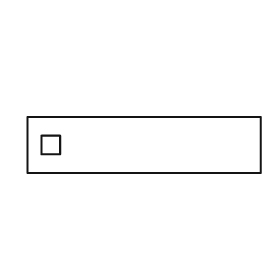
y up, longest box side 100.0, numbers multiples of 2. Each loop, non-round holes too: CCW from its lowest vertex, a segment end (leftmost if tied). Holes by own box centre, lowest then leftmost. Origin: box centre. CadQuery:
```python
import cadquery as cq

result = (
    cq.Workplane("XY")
    .moveTo(-50.0, -12.0)
    .lineTo(50.0, -12.0)
    .lineTo(50.0, 12.0)
    .lineTo(-50.0, 12.0)
    .close()
    .moveTo(-44.0, -4.0)
    .lineTo(-36.0, -4.0)
    .lineTo(-36.0, 4.0)
    .lineTo(-44.0, 4.0)
    .close()
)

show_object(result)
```